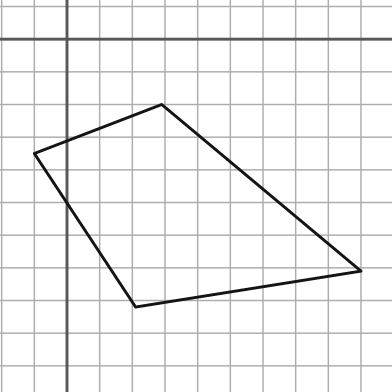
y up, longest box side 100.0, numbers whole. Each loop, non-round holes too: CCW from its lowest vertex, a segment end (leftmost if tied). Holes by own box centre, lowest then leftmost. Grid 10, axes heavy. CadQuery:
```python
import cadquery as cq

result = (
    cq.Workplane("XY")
    .moveTo(21.0, -82.0)
    .lineTo(90.0, -71.0)
    .lineTo(29.0, -20.0)
    .lineTo(-10.0, -35.0)
    .close()
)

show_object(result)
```